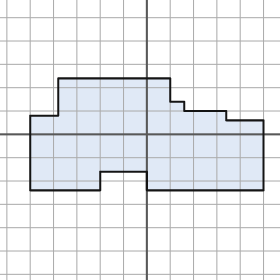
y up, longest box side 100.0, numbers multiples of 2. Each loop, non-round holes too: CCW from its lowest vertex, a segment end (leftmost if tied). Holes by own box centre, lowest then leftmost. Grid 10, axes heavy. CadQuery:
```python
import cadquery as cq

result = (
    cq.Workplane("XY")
    .moveTo(-50.0, -24.0)
    .lineTo(-20.0, -24.0)
    .lineTo(-20.0, -16.0)
    .lineTo(0.0, -16.0)
    .lineTo(0.0, -24.0)
    .lineTo(50.0, -24.0)
    .lineTo(50.0, 6.0)
    .lineTo(34.0, 6.0)
    .lineTo(34.0, 10.0)
    .lineTo(16.0, 10.0)
    .lineTo(16.0, 14.0)
    .lineTo(10.0, 14.0)
    .lineTo(10.0, 24.0)
    .lineTo(-38.0, 24.0)
    .lineTo(-38.0, 8.0)
    .lineTo(-50.0, 8.0)
    .close()
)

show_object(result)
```